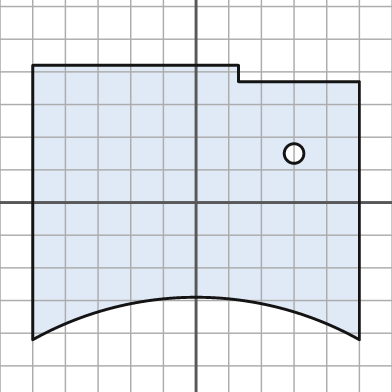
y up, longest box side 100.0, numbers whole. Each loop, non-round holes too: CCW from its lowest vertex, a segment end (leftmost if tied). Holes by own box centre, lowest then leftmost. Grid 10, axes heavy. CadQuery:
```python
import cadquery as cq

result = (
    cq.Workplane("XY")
    .moveTo(-50.0, -42.0)
    .threePointArc((0.0, -29.0), (50.0, -42.0))
    .lineTo(50.0, 37.0)
    .lineTo(13.0, 37.0)
    .lineTo(13.0, 42.0)
    .lineTo(-50.0, 42.0)
    .close()
    .moveTo(30.0, 15.0)
    .circle(3.0)
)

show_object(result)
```